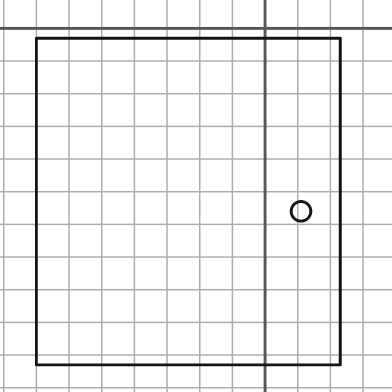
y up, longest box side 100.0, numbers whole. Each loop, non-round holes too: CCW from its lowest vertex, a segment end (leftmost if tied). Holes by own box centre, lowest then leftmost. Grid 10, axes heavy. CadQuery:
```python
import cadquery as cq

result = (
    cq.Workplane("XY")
    .moveTo(-70.0, -103.0)
    .lineTo(23.0, -103.0)
    .lineTo(23.0, -3.0)
    .lineTo(-70.0, -3.0)
    .close()
    .moveTo(11.0, -56.0)
    .circle(3.0)
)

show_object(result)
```